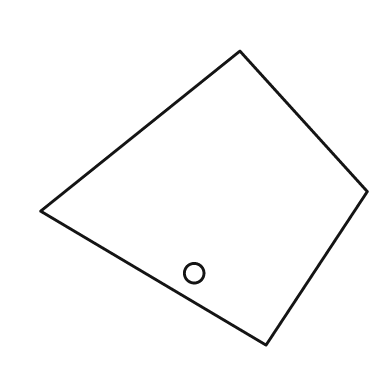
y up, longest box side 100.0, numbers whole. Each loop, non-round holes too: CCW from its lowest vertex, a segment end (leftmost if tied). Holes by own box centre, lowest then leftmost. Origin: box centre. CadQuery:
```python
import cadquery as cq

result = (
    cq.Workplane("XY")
    .moveTo(19.0, -45.0)
    .lineTo(50.0, 2.0)
    .lineTo(11.0, 45.0)
    .lineTo(-50.0, -4.0)
    .close()
    .moveTo(-3.0, -23.0)
    .circle(3.0)
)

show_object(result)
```